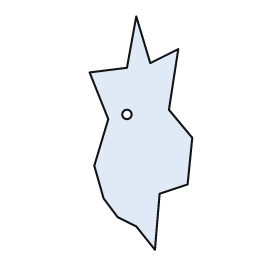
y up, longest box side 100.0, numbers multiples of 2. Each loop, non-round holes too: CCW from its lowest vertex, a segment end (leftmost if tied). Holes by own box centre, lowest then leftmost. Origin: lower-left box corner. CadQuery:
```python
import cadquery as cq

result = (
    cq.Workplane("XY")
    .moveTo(28.0, 0.0)
    .lineTo(30.0, 24.0)
    .lineTo(42.0, 28.0)
    .lineTo(44.0, 48.0)
    .lineTo(34.0, 60.0)
    .lineTo(38.0, 86.0)
    .lineTo(26.0, 80.0)
    .lineTo(20.0, 100.0)
    .lineTo(16.0, 78.0)
    .lineTo(0.0, 76.0)
    .lineTo(8.0, 56.0)
    .lineTo(2.0, 36.0)
    .lineTo(6.0, 22.0)
    .lineTo(12.0, 14.0)
    .lineTo(20.0, 10.0)
    .close()
    .moveTo(16.0, 58.0)
    .circle(2.0)
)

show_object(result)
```